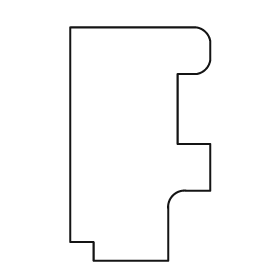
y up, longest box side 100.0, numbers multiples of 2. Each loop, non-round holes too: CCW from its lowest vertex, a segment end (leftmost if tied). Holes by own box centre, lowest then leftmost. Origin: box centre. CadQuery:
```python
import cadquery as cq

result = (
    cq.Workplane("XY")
    .moveTo(-20.0, -50.0)
    .lineTo(12.0, -50.0)
    .lineTo(12.0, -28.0)
    .threePointArc((14.0, -22.0), (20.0, -20.0))
    .lineTo(30.0, -20.0)
    .lineTo(30.0, 0.0)
    .lineTo(16.0, 0.0)
    .lineTo(16.0, 30.0)
    .lineTo(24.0, 30.0)
    .threePointArc((28.0, 32.0), (30.0, 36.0))
    .lineTo(30.0, 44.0)
    .threePointArc((28.0, 48.0), (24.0, 50.0))
    .lineTo(-30.0, 50.0)
    .lineTo(-30.0, -42.0)
    .lineTo(-20.0, -42.0)
    .close()
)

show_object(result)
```